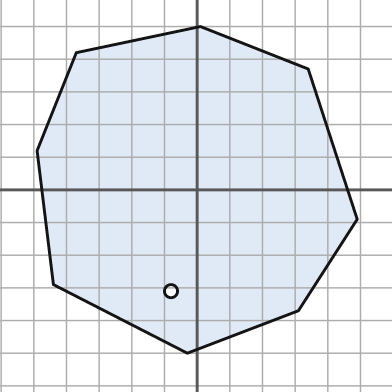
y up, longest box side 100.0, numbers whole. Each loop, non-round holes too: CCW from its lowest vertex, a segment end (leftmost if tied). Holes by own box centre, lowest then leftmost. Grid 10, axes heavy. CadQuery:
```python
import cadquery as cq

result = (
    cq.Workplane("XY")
    .moveTo(-3.0, -50.0)
    .lineTo(31.0, -37.0)
    .lineTo(49.0, -9.0)
    .lineTo(34.0, 37.0)
    .lineTo(1.0, 50.0)
    .lineTo(-37.0, 42.0)
    .lineTo(-49.0, 12.0)
    .lineTo(-44.0, -29.0)
    .close()
    .moveTo(-8.0, -31.0)
    .circle(2.0)
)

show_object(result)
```